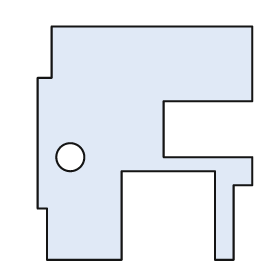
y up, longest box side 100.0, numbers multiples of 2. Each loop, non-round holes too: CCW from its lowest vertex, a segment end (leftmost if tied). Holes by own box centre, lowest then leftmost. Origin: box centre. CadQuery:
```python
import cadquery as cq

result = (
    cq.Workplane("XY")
    .moveTo(-42.0, -50.0)
    .lineTo(-10.0, -50.0)
    .lineTo(-10.0, -12.0)
    .lineTo(30.0, -12.0)
    .lineTo(30.0, -50.0)
    .lineTo(38.0, -50.0)
    .lineTo(38.0, -18.0)
    .lineTo(46.0, -18.0)
    .lineTo(46.0, -6.0)
    .lineTo(8.0, -6.0)
    .lineTo(8.0, 18.0)
    .lineTo(46.0, 18.0)
    .lineTo(46.0, 50.0)
    .lineTo(-40.0, 50.0)
    .lineTo(-40.0, 28.0)
    .lineTo(-46.0, 28.0)
    .lineTo(-46.0, -28.0)
    .lineTo(-42.0, -28.0)
    .close()
    .moveTo(-32.0, -6.0)
    .circle(6.0)
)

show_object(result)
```